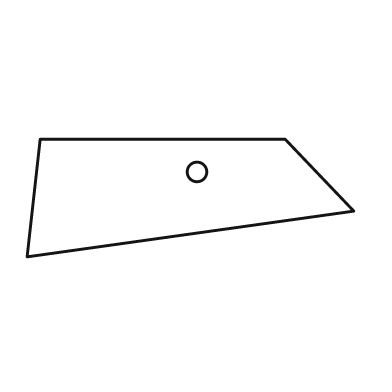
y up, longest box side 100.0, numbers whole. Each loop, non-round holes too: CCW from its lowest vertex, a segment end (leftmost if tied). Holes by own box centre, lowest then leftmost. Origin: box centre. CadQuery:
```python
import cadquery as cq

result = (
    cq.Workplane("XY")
    .moveTo(-50.0, -18.0)
    .lineTo(50.0, -4.0)
    .lineTo(29.0, 18.0)
    .lineTo(-46.0, 18.0)
    .close()
    .moveTo(2.0, 8.0)
    .circle(3.0)
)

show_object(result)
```